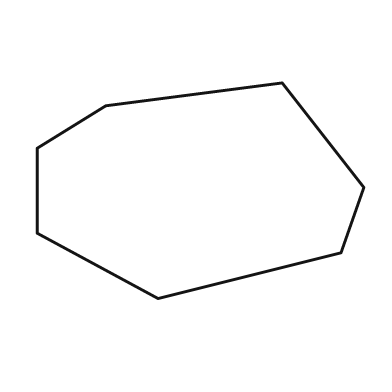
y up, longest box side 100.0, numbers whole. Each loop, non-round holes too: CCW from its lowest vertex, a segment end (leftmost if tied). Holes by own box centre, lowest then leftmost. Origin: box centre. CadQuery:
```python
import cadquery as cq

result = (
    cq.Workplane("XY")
    .moveTo(-13.0, -33.0)
    .lineTo(43.0, -19.0)
    .lineTo(50.0, 1.0)
    .lineTo(25.0, 33.0)
    .lineTo(-29.0, 26.0)
    .lineTo(-50.0, 13.0)
    .lineTo(-50.0, -13.0)
    .close()
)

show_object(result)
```